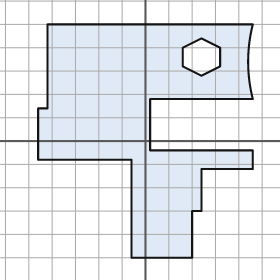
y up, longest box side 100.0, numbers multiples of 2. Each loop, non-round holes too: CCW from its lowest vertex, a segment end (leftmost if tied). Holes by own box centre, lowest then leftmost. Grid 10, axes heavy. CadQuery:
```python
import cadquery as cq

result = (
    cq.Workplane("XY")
    .moveTo(-6.0, -50.0)
    .lineTo(20.0, -50.0)
    .lineTo(20.0, -30.0)
    .lineTo(24.0, -30.0)
    .lineTo(24.0, -12.0)
    .lineTo(46.0, -12.0)
    .lineTo(46.0, -4.0)
    .lineTo(2.0, -4.0)
    .lineTo(2.0, 18.0)
    .lineTo(46.0, 18.0)
    .threePointArc((44.0, 34.0), (46.0, 50.0))
    .lineTo(-42.0, 50.0)
    .lineTo(-42.0, 14.0)
    .lineTo(-46.0, 14.0)
    .lineTo(-46.0, -8.0)
    .lineTo(-6.0, -8.0)
    .close()
    .moveTo(24.0, 28.0)
    .lineTo(32.0, 32.0)
    .lineTo(32.0, 40.0)
    .lineTo(24.0, 44.0)
    .lineTo(16.0, 40.0)
    .lineTo(16.0, 32.0)
    .close()
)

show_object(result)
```